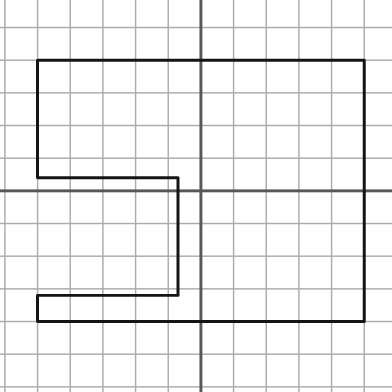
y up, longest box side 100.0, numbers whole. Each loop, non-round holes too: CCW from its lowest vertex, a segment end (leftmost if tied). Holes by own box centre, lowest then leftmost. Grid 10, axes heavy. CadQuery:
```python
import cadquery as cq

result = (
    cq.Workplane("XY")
    .moveTo(-50.0, -40.0)
    .lineTo(50.0, -40.0)
    .lineTo(50.0, 40.0)
    .lineTo(-50.0, 40.0)
    .lineTo(-50.0, 4.0)
    .lineTo(-7.0, 4.0)
    .lineTo(-7.0, -32.0)
    .lineTo(-50.0, -32.0)
    .close()
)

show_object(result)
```